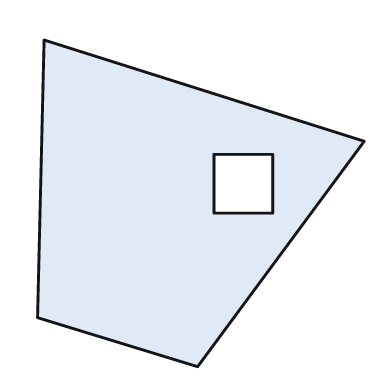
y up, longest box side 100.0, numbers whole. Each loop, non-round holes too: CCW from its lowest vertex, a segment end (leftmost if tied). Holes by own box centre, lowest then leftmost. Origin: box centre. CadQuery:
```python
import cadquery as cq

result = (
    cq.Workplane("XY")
    .moveTo(-1.0, -50.0)
    .lineTo(50.0, 19.0)
    .lineTo(-48.0, 50.0)
    .lineTo(-50.0, -35.0)
    .close()
    .moveTo(4.0, -3.0)
    .lineTo(22.0, -3.0)
    .lineTo(22.0, 15.0)
    .lineTo(4.0, 15.0)
    .close()
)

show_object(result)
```